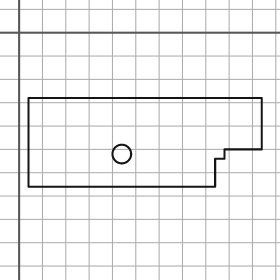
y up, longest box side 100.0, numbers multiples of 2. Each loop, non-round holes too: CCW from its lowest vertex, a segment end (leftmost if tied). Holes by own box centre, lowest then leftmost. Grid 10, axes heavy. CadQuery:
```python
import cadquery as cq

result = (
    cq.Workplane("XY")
    .moveTo(4.0, -66.0)
    .lineTo(84.0, -66.0)
    .lineTo(84.0, -54.0)
    .lineTo(88.0, -54.0)
    .lineTo(88.0, -50.0)
    .lineTo(104.0, -50.0)
    .lineTo(104.0, -28.0)
    .lineTo(4.0, -28.0)
    .close()
    .moveTo(44.0, -52.0)
    .circle(4.0)
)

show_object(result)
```